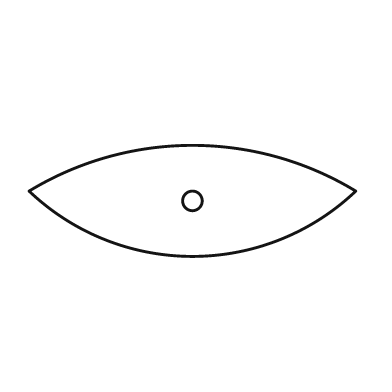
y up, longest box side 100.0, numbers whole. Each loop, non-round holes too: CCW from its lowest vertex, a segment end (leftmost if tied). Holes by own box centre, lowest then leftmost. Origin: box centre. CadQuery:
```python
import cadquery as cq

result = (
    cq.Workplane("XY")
    .moveTo(-50.0, 3.0)
    .threePointArc((0.0, -17.0), (50.0, 3.0))
    .threePointArc((0.0, 17.0), (-50.0, 3.0))
    .close()
    .moveTo(0.0, 0.0)
    .circle(3.0)
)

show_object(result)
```